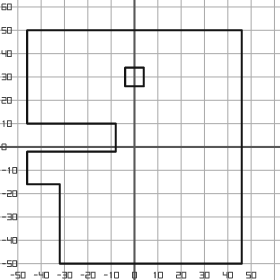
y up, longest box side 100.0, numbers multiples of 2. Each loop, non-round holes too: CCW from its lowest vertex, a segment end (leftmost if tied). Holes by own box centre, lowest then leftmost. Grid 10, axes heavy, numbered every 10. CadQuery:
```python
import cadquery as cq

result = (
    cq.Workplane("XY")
    .moveTo(-32.0, -50.0)
    .lineTo(46.0, -50.0)
    .lineTo(46.0, 50.0)
    .lineTo(-46.0, 50.0)
    .lineTo(-46.0, 10.0)
    .lineTo(-8.0, 10.0)
    .lineTo(-8.0, -2.0)
    .lineTo(-46.0, -2.0)
    .lineTo(-46.0, -16.0)
    .lineTo(-32.0, -16.0)
    .close()
    .moveTo(-4.0, 26.0)
    .lineTo(4.0, 26.0)
    .lineTo(4.0, 34.0)
    .lineTo(-4.0, 34.0)
    .close()
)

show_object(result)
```